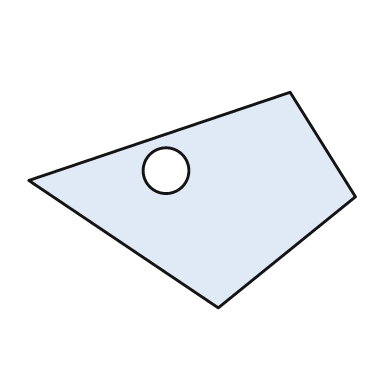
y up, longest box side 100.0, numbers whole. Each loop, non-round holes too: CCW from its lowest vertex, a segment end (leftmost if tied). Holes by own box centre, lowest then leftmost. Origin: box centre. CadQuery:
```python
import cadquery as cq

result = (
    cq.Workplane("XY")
    .moveTo(8.0, -33.0)
    .lineTo(50.0, 1.0)
    .lineTo(30.0, 33.0)
    .lineTo(-50.0, 6.0)
    .close()
    .moveTo(-8.0, 9.0)
    .circle(7.0)
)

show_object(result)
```